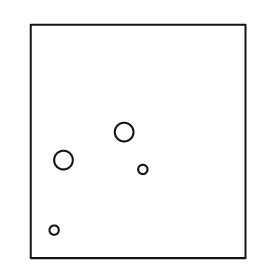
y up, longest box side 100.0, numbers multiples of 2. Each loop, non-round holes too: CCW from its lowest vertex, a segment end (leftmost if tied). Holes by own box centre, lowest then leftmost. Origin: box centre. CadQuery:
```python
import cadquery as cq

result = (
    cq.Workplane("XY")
    .moveTo(-46.0, -50.0)
    .lineTo(46.0, -50.0)
    .lineTo(46.0, 50.0)
    .lineTo(-46.0, 50.0)
    .close()
    .moveTo(-36.0, -38.0)
    .circle(2.0)
    .moveTo(2.0, -12.0)
    .circle(2.0)
    .moveTo(-32.0, -8.0)
    .circle(4.0)
    .moveTo(-6.0, 4.0)
    .circle(4.0)
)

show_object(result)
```